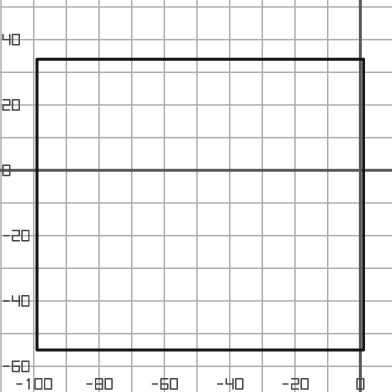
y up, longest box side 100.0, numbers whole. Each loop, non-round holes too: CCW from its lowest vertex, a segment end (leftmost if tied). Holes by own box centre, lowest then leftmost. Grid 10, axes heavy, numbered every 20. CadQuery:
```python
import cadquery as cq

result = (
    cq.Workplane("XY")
    .moveTo(-99.0, -55.0)
    .lineTo(1.0, -55.0)
    .lineTo(1.0, 34.0)
    .lineTo(-99.0, 34.0)
    .close()
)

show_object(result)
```